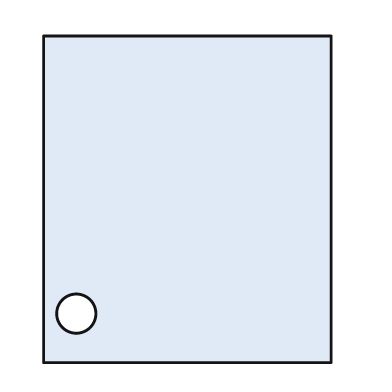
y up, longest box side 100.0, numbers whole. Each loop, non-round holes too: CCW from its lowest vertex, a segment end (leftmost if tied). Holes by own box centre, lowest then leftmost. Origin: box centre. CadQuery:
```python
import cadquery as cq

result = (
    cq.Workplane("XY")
    .moveTo(-44.0, -50.0)
    .lineTo(44.0, -50.0)
    .lineTo(44.0, 50.0)
    .lineTo(-44.0, 50.0)
    .close()
    .moveTo(-34.0, -35.0)
    .circle(6.0)
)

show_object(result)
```